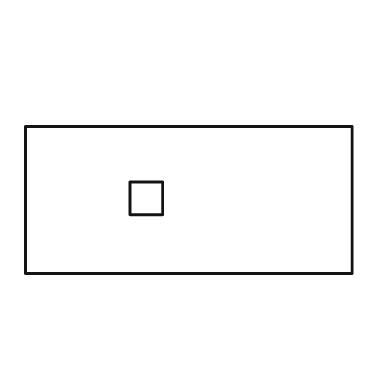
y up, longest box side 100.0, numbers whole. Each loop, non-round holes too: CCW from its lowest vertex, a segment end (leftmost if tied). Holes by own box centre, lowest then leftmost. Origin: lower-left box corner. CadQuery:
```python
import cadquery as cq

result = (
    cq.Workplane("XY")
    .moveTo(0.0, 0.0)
    .lineTo(100.0, 0.0)
    .lineTo(100.0, 45.0)
    .lineTo(0.0, 45.0)
    .close()
    .moveTo(32.0, 18.0)
    .lineTo(42.0, 18.0)
    .lineTo(42.0, 28.0)
    .lineTo(32.0, 28.0)
    .close()
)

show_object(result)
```